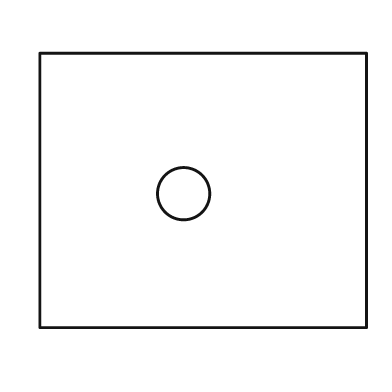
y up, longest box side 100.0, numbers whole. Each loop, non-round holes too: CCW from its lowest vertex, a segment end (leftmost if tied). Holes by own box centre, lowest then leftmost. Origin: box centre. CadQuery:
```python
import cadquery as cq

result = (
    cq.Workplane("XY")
    .moveTo(-50.0, -42.0)
    .lineTo(50.0, -42.0)
    .lineTo(50.0, 42.0)
    .lineTo(-50.0, 42.0)
    .close()
    .moveTo(-6.0, -1.0)
    .circle(8.0)
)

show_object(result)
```